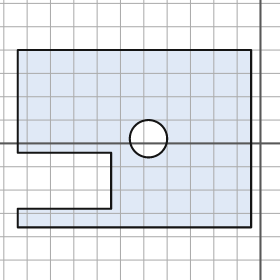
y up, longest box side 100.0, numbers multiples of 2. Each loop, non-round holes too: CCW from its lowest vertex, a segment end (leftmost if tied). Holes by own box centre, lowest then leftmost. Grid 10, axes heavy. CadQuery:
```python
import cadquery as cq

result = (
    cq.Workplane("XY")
    .moveTo(-104.0, -36.0)
    .lineTo(-4.0, -36.0)
    .lineTo(-4.0, 40.0)
    .lineTo(-104.0, 40.0)
    .lineTo(-104.0, -4.0)
    .lineTo(-64.0, -4.0)
    .lineTo(-64.0, -28.0)
    .lineTo(-104.0, -28.0)
    .close()
    .moveTo(-48.0, 2.0)
    .circle(8.0)
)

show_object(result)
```